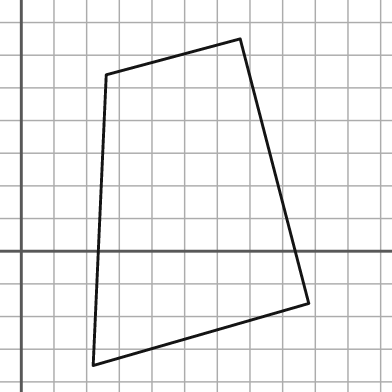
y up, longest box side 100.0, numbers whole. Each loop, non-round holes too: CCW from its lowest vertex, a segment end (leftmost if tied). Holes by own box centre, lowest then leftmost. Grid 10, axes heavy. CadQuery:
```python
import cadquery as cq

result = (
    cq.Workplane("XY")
    .moveTo(22.0, -35.0)
    .lineTo(88.0, -16.0)
    .lineTo(67.0, 65.0)
    .lineTo(26.0, 54.0)
    .close()
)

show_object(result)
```